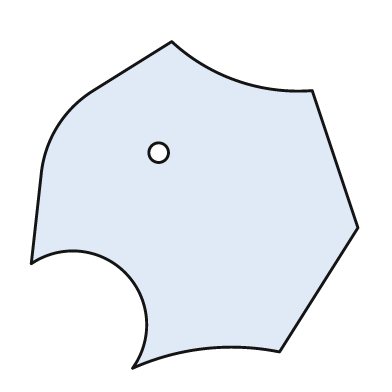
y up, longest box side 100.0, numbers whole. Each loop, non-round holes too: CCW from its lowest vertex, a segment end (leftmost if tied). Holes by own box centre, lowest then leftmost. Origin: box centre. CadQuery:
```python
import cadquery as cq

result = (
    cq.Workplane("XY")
    .moveTo(-19.0, -50.0)
    .threePointArc((3.0, -44.0), (26.0, -45.0))
    .lineTo(50.0, -7.0)
    .lineTo(36.0, 35.0)
    .threePointArc((13.0, 38.0), (-7.0, 50.0))
    .lineTo(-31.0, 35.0)
    .threePointArc((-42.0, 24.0), (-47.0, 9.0))
    .lineTo(-50.0, -18.0)
    .threePointArc((-21.0, -21.0), (-19.0, -50.0))
    .close()
    .moveTo(-11.0, 16.0)
    .circle(3.0)
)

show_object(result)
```